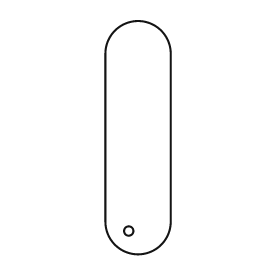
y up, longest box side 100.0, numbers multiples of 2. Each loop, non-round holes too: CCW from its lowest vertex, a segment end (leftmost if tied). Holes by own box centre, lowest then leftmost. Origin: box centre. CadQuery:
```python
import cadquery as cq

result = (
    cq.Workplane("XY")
    .moveTo(-14.0, -36.0)
    .threePointArc((0.0, -50.0), (14.0, -36.0))
    .lineTo(14.0, 36.0)
    .threePointArc((0.0, 50.0), (-14.0, 36.0))
    .close()
    .moveTo(-4.0, -40.0)
    .circle(2.0)
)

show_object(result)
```